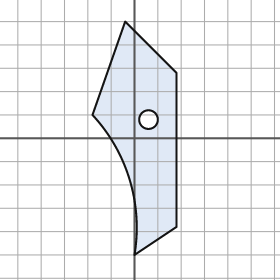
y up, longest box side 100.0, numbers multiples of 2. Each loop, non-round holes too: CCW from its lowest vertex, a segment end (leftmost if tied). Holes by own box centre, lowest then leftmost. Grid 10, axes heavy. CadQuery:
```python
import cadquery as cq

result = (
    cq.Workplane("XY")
    .moveTo(0.0, -50.0)
    .lineTo(18.0, -38.0)
    .lineTo(18.0, 28.0)
    .lineTo(-4.0, 50.0)
    .lineTo(-18.0, 10.0)
    .threePointArc((-2.0, -18.0), (0.0, -50.0))
    .close()
    .moveTo(6.0, 8.0)
    .circle(4.0)
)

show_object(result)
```